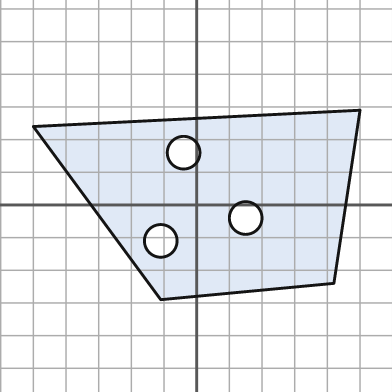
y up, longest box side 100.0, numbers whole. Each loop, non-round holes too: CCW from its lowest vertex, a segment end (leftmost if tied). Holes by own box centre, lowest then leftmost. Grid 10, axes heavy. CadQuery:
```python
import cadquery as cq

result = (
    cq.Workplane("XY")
    .moveTo(-11.0, -29.0)
    .lineTo(42.0, -24.0)
    .lineTo(50.0, 29.0)
    .lineTo(-50.0, 24.0)
    .close()
    .moveTo(-11.0, -11.0)
    .circle(5.0)
    .moveTo(15.0, -4.0)
    .circle(5.0)
    .moveTo(-4.0, 16.0)
    .circle(5.0)
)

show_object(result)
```